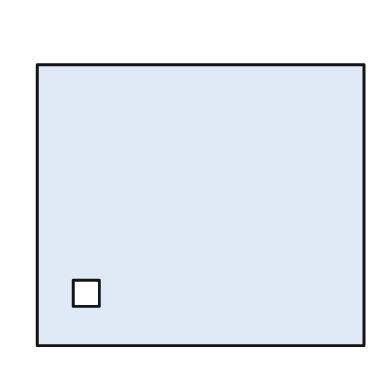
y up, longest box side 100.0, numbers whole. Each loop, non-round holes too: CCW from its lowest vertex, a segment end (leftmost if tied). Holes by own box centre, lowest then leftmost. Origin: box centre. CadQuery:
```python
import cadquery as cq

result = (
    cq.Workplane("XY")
    .moveTo(-50.0, -43.0)
    .lineTo(50.0, -43.0)
    .lineTo(50.0, 43.0)
    .lineTo(-50.0, 43.0)
    .close()
    .moveTo(-39.0, -31.0)
    .lineTo(-31.0, -31.0)
    .lineTo(-31.0, -23.0)
    .lineTo(-39.0, -23.0)
    .close()
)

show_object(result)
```